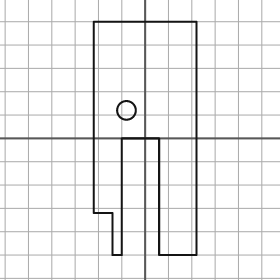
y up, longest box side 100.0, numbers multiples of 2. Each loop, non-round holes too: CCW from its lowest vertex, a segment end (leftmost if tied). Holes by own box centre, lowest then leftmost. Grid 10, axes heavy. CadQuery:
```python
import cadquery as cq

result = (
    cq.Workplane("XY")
    .moveTo(-14.0, -50.0)
    .lineTo(-10.0, -50.0)
    .lineTo(-10.0, 0.0)
    .lineTo(6.0, 0.0)
    .lineTo(6.0, -50.0)
    .lineTo(22.0, -50.0)
    .lineTo(22.0, 50.0)
    .lineTo(-22.0, 50.0)
    .lineTo(-22.0, -32.0)
    .lineTo(-14.0, -32.0)
    .close()
    .moveTo(-8.0, 12.0)
    .circle(4.0)
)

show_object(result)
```